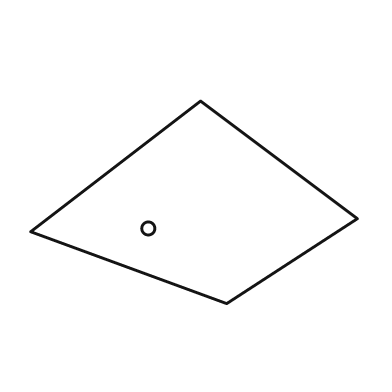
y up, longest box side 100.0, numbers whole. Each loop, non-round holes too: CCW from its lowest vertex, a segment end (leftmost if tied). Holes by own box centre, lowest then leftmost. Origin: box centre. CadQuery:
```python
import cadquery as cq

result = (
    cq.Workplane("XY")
    .moveTo(10.0, -31.0)
    .lineTo(50.0, -5.0)
    .lineTo(2.0, 31.0)
    .lineTo(-50.0, -9.0)
    .close()
    .moveTo(-14.0, -8.0)
    .circle(2.0)
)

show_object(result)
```